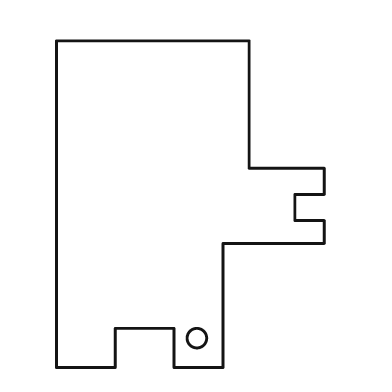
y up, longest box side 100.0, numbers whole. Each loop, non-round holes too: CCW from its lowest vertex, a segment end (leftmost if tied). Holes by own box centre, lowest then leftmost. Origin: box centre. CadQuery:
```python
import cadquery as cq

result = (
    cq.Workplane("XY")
    .moveTo(-41.0, -50.0)
    .lineTo(-23.0, -50.0)
    .lineTo(-23.0, -38.0)
    .lineTo(-5.0, -38.0)
    .lineTo(-5.0, -50.0)
    .lineTo(10.0, -50.0)
    .lineTo(10.0, -12.0)
    .lineTo(41.0, -12.0)
    .lineTo(41.0, -5.0)
    .lineTo(32.0, -5.0)
    .lineTo(32.0, 3.0)
    .lineTo(41.0, 3.0)
    .lineTo(41.0, 11.0)
    .lineTo(18.0, 11.0)
    .lineTo(18.0, 50.0)
    .lineTo(-41.0, 50.0)
    .close()
    .moveTo(2.0, -41.0)
    .circle(3.0)
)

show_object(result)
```